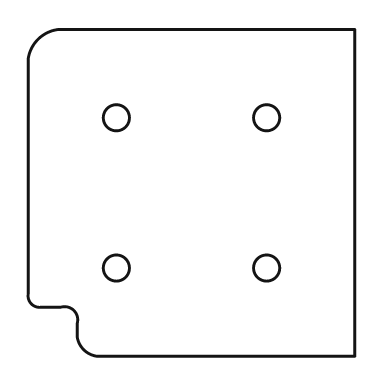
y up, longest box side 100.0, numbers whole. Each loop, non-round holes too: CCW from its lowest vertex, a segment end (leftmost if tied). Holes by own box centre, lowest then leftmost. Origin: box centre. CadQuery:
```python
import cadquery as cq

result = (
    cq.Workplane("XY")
    .moveTo(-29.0, -50.0)
    .lineTo(50.0, -50.0)
    .lineTo(50.0, 50.0)
    .lineTo(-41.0, 50.0)
    .threePointArc((-47.0, 47.0), (-50.0, 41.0))
    .lineTo(-50.0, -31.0)
    .threePointArc((-49.0, -34.0), (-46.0, -35.0))
    .lineTo(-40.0, -35.0)
    .threePointArc((-36.0, -36.0), (-35.0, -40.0))
    .lineTo(-35.0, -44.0)
    .threePointArc((-33.0, -48.0), (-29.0, -50.0))
    .close()
    .moveTo(-23.0, -23.0)
    .circle(4.0)
    .moveTo(23.0, -23.0)
    .circle(4.0)
    .moveTo(-23.0, 23.0)
    .circle(4.0)
    .moveTo(23.0, 23.0)
    .circle(4.0)
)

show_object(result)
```